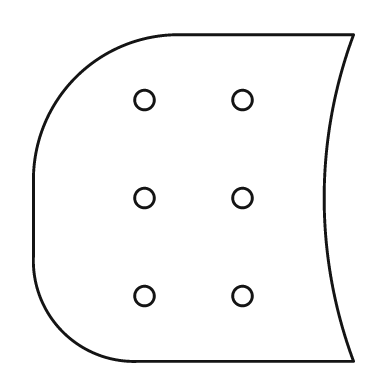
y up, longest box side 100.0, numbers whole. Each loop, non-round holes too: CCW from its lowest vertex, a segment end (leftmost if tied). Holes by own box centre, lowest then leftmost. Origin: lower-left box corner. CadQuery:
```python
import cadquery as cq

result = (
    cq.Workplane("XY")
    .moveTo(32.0, 0.0)
    .lineTo(98.0, 0.0)
    .threePointArc((89.0, 50.0), (98.0, 100.0))
    .lineTo(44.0, 100.0)
    .threePointArc((13.0, 87.0), (0.0, 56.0))
    .lineTo(0.0, 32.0)
    .threePointArc((9.0, 9.0), (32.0, 0.0))
    .close()
    .moveTo(34.0, 20.0)
    .circle(3.0)
    .moveTo(64.0, 20.0)
    .circle(3.0)
    .moveTo(34.0, 50.0)
    .circle(3.0)
    .moveTo(64.0, 50.0)
    .circle(3.0)
    .moveTo(34.0, 80.0)
    .circle(3.0)
    .moveTo(64.0, 80.0)
    .circle(3.0)
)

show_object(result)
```